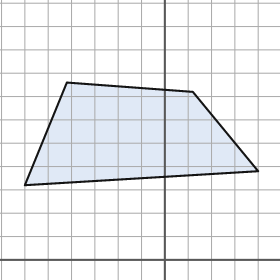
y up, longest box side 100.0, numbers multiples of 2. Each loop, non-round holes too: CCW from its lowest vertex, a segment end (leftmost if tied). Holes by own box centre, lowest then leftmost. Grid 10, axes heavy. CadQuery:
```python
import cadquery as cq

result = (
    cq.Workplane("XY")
    .moveTo(-60.0, 32.0)
    .lineTo(40.0, 38.0)
    .lineTo(12.0, 72.0)
    .lineTo(-42.0, 76.0)
    .close()
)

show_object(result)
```